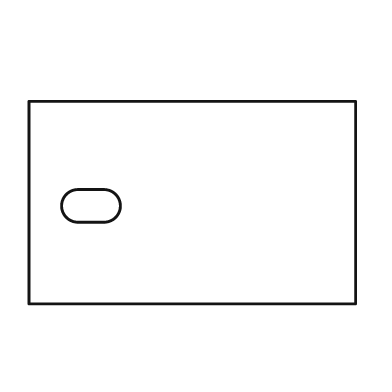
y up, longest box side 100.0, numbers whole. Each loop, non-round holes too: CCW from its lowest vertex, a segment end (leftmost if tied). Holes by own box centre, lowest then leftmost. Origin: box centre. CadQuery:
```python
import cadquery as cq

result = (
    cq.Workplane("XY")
    .moveTo(-50.0, -31.0)
    .lineTo(50.0, -31.0)
    .lineTo(50.0, 31.0)
    .lineTo(-50.0, 31.0)
    .close()
    .moveTo(-35.0, -6.0)
    .lineTo(-27.0, -6.0)
    .threePointArc((-22.0, -1.0), (-27.0, 4.0))
    .lineTo(-35.0, 4.0)
    .threePointArc((-40.0, -1.0), (-35.0, -6.0))
    .close()
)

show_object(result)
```